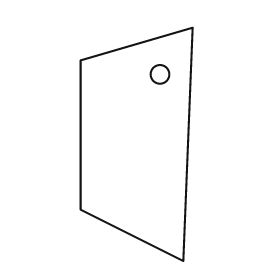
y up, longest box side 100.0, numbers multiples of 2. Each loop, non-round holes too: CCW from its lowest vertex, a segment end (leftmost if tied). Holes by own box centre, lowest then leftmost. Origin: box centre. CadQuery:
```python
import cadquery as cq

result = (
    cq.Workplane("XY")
    .moveTo(20.0, -50.0)
    .lineTo(24.0, 50.0)
    .lineTo(-24.0, 36.0)
    .lineTo(-24.0, -28.0)
    .close()
    .moveTo(10.0, 30.0)
    .circle(4.0)
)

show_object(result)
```